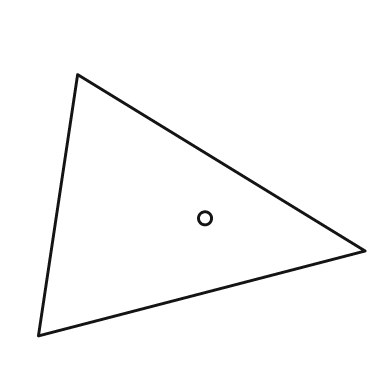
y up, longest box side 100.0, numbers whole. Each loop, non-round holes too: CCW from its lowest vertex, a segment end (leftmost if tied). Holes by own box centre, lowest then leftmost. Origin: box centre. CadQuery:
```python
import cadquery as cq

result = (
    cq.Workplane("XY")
    .moveTo(-50.0, -40.0)
    .lineTo(50.0, -14.0)
    .lineTo(-38.0, 40.0)
    .close()
    .moveTo(1.0, -4.0)
    .circle(2.0)
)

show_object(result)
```